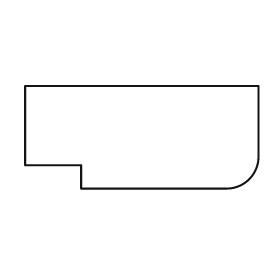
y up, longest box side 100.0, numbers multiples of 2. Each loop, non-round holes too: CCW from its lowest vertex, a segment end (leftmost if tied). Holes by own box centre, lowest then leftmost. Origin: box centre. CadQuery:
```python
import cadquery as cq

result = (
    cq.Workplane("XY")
    .moveTo(-26.0, -22.0)
    .lineTo(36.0, -22.0)
    .threePointArc((46.0, -18.0), (50.0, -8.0))
    .lineTo(50.0, 22.0)
    .lineTo(-50.0, 22.0)
    .lineTo(-50.0, -12.0)
    .lineTo(-26.0, -12.0)
    .close()
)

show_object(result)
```